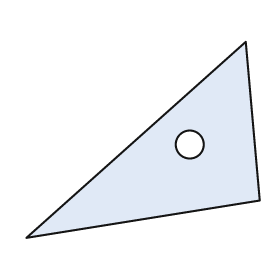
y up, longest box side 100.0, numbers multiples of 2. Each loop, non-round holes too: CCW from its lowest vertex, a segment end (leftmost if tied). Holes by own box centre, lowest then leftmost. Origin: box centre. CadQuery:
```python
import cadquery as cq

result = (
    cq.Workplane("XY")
    .moveTo(-50.0, -42.0)
    .lineTo(50.0, -26.0)
    .lineTo(44.0, 42.0)
    .close()
    .moveTo(20.0, -2.0)
    .circle(6.0)
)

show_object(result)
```